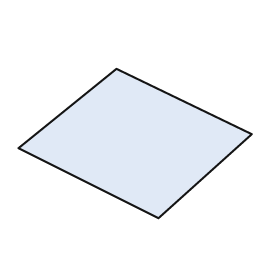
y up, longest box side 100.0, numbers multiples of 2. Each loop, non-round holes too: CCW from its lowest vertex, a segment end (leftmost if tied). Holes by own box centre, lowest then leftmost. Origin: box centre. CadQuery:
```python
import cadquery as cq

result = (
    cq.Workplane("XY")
    .moveTo(10.0, -32.0)
    .lineTo(50.0, 4.0)
    .lineTo(-8.0, 32.0)
    .lineTo(-50.0, -2.0)
    .close()
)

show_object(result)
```